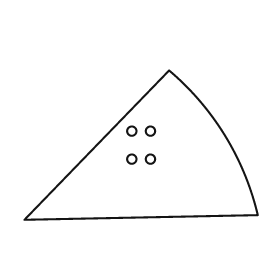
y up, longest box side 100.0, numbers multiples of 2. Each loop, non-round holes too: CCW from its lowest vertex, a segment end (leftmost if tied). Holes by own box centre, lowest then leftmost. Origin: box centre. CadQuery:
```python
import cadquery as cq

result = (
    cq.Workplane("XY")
    .moveTo(-50.0, -32.0)
    .lineTo(50.0, -30.0)
    .threePointArc((36.0, 4.0), (12.0, 32.0))
    .close()
    .moveTo(-4.0, -6.0)
    .circle(2.0)
    .moveTo(4.0, -6.0)
    .circle(2.0)
    .moveTo(-4.0, 6.0)
    .circle(2.0)
    .moveTo(4.0, 6.0)
    .circle(2.0)
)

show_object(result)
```